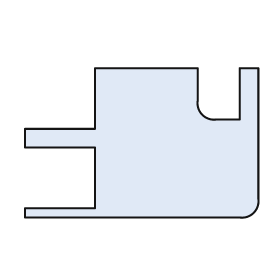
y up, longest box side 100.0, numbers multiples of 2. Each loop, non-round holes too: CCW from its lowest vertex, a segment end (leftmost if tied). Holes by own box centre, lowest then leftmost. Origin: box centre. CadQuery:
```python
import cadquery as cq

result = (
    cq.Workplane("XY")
    .moveTo(-50.0, -32.0)
    .lineTo(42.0, -32.0)
    .threePointArc((48.0, -30.0), (50.0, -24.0))
    .lineTo(50.0, 32.0)
    .lineTo(42.0, 32.0)
    .lineTo(42.0, 10.0)
    .lineTo(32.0, 10.0)
    .threePointArc((26.0, 12.0), (24.0, 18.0))
    .lineTo(24.0, 32.0)
    .lineTo(-20.0, 32.0)
    .lineTo(-20.0, 6.0)
    .lineTo(-50.0, 6.0)
    .lineTo(-50.0, -2.0)
    .lineTo(-20.0, -2.0)
    .lineTo(-20.0, -28.0)
    .lineTo(-50.0, -28.0)
    .close()
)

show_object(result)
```